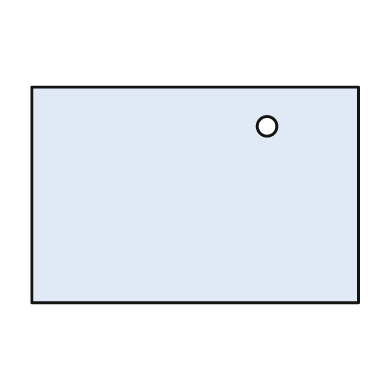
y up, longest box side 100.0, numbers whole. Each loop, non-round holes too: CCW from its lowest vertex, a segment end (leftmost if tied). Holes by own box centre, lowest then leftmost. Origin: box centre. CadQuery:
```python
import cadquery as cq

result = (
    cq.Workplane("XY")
    .moveTo(-50.0, -33.0)
    .lineTo(50.0, -33.0)
    .lineTo(50.0, 33.0)
    .lineTo(-50.0, 33.0)
    .close()
    .moveTo(22.0, 21.0)
    .circle(3.0)
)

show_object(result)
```